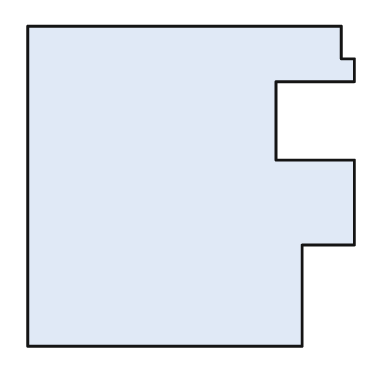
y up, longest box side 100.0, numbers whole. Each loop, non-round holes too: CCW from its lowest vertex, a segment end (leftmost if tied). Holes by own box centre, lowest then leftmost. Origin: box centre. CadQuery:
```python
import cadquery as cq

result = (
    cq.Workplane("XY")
    .moveTo(-50.0, -49.0)
    .lineTo(34.0, -49.0)
    .lineTo(34.0, -18.0)
    .lineTo(50.0, -18.0)
    .lineTo(50.0, 8.0)
    .lineTo(26.0, 8.0)
    .lineTo(26.0, 32.0)
    .lineTo(50.0, 32.0)
    .lineTo(50.0, 39.0)
    .lineTo(46.0, 39.0)
    .lineTo(46.0, 49.0)
    .lineTo(-50.0, 49.0)
    .close()
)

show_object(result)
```